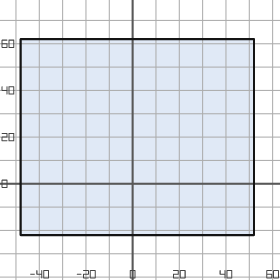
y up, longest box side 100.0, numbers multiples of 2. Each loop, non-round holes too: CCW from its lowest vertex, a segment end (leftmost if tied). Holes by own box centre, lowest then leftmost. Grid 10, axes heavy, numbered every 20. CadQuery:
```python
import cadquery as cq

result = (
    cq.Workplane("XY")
    .moveTo(-48.0, -22.0)
    .lineTo(52.0, -22.0)
    .lineTo(52.0, 62.0)
    .lineTo(-48.0, 62.0)
    .close()
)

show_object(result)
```